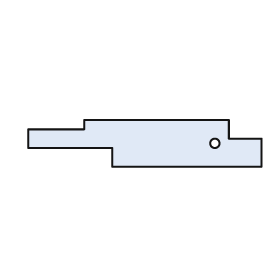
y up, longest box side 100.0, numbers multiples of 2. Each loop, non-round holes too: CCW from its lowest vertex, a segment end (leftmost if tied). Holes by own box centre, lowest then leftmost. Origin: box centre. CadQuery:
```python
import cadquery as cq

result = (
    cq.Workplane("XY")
    .moveTo(-14.0, -10.0)
    .lineTo(50.0, -10.0)
    .lineTo(50.0, 2.0)
    .lineTo(36.0, 2.0)
    .lineTo(36.0, 10.0)
    .lineTo(-26.0, 10.0)
    .lineTo(-26.0, 6.0)
    .lineTo(-50.0, 6.0)
    .lineTo(-50.0, -2.0)
    .lineTo(-14.0, -2.0)
    .close()
    .moveTo(30.0, 0.0)
    .circle(2.0)
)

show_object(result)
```